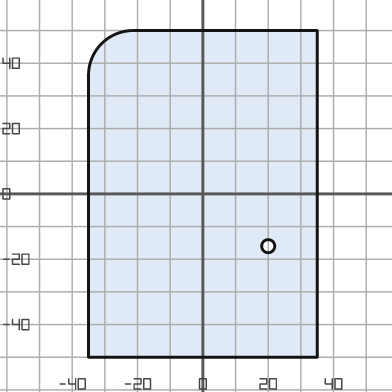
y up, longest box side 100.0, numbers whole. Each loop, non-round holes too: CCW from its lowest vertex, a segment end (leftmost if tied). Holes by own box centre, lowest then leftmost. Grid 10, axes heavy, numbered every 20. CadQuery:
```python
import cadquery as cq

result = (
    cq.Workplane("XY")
    .moveTo(-35.0, -50.0)
    .lineTo(35.0, -50.0)
    .lineTo(35.0, 50.0)
    .lineTo(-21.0, 50.0)
    .threePointArc((-31.0, 46.0), (-35.0, 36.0))
    .close()
    .moveTo(20.0, -16.0)
    .circle(2.0)
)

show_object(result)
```